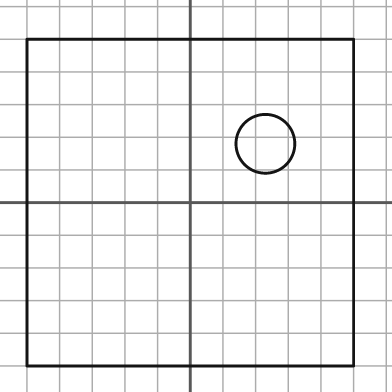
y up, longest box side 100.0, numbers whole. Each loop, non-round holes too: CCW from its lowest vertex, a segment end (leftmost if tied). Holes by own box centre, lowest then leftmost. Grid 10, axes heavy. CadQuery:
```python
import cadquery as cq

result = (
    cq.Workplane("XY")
    .moveTo(-50.0, -50.0)
    .lineTo(50.0, -50.0)
    .lineTo(50.0, 50.0)
    .lineTo(-50.0, 50.0)
    .close()
    .moveTo(23.0, 18.0)
    .circle(9.0)
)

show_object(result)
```